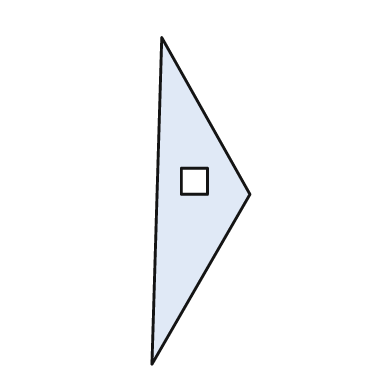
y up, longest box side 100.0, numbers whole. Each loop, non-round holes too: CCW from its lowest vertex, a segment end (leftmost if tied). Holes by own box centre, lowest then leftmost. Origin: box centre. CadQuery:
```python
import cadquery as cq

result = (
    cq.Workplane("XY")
    .moveTo(-15.0, -50.0)
    .lineTo(15.0, 2.0)
    .lineTo(-12.0, 50.0)
    .close()
    .moveTo(-6.0, 2.0)
    .lineTo(2.0, 2.0)
    .lineTo(2.0, 10.0)
    .lineTo(-6.0, 10.0)
    .close()
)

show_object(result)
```